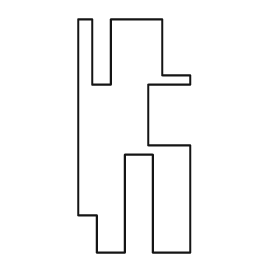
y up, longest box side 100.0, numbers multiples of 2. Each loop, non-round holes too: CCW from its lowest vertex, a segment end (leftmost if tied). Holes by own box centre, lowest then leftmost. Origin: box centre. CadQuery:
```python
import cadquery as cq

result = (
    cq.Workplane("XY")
    .moveTo(-16.0, -50.0)
    .lineTo(-4.0, -50.0)
    .lineTo(-4.0, -8.0)
    .lineTo(8.0, -8.0)
    .lineTo(8.0, -50.0)
    .lineTo(24.0, -50.0)
    .lineTo(24.0, -4.0)
    .lineTo(6.0, -4.0)
    .lineTo(6.0, 22.0)
    .lineTo(24.0, 22.0)
    .lineTo(24.0, 26.0)
    .lineTo(12.0, 26.0)
    .lineTo(12.0, 50.0)
    .lineTo(-10.0, 50.0)
    .lineTo(-10.0, 22.0)
    .lineTo(-18.0, 22.0)
    .lineTo(-18.0, 50.0)
    .lineTo(-24.0, 50.0)
    .lineTo(-24.0, -34.0)
    .lineTo(-16.0, -34.0)
    .close()
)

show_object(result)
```